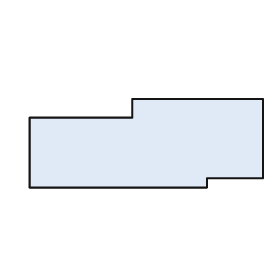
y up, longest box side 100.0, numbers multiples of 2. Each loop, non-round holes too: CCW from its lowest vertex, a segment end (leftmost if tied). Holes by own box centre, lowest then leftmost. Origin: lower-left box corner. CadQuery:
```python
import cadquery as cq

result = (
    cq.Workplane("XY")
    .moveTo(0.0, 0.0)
    .lineTo(76.0, 0.0)
    .lineTo(76.0, 4.0)
    .lineTo(100.0, 4.0)
    .lineTo(100.0, 38.0)
    .lineTo(44.0, 38.0)
    .lineTo(44.0, 30.0)
    .lineTo(0.0, 30.0)
    .close()
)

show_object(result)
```